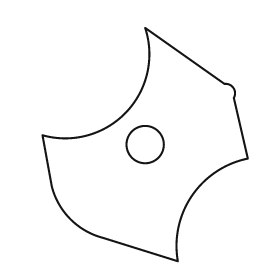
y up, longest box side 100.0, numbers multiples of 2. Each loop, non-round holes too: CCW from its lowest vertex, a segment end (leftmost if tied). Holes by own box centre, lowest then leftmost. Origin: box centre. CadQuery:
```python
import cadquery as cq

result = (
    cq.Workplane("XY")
    .moveTo(14.0, -50.0)
    .threePointArc((20.0, -22.0), (44.0, -6.0))
    .lineTo(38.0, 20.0)
    .threePointArc((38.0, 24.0), (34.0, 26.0))
    .lineTo(0.0, 50.0)
    .threePointArc((-8.0, 14.0), (-44.0, 4.0))
    .lineTo(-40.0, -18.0)
    .threePointArc((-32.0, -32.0), (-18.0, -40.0))
    .close()
    .moveTo(0.0, 0.0)
    .circle(8.0)
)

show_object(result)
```